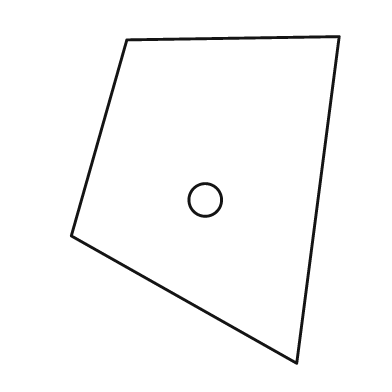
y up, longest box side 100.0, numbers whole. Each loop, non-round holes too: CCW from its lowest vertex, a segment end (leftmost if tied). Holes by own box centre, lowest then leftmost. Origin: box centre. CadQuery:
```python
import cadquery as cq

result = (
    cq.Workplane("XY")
    .moveTo(28.0, -50.0)
    .lineTo(41.0, 50.0)
    .lineTo(-24.0, 49.0)
    .lineTo(-41.0, -11.0)
    .close()
    .moveTo(0.0, 0.0)
    .circle(5.0)
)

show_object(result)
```